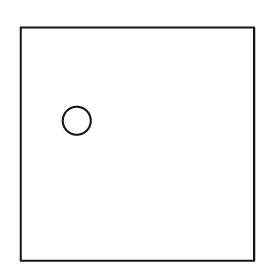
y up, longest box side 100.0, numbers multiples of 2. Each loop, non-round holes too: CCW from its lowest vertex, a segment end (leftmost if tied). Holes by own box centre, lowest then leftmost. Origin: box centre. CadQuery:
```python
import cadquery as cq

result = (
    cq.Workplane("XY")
    .moveTo(-50.0, -50.0)
    .lineTo(50.0, -50.0)
    .lineTo(50.0, 50.0)
    .lineTo(-50.0, 50.0)
    .close()
    .moveTo(-26.0, 10.0)
    .circle(6.0)
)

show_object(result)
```